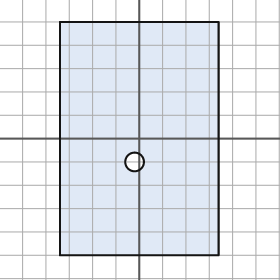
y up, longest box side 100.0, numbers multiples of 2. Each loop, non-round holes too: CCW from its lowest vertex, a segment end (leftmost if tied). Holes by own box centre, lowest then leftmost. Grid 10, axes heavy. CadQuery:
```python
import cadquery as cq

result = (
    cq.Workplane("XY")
    .moveTo(-34.0, -50.0)
    .lineTo(34.0, -50.0)
    .lineTo(34.0, 50.0)
    .lineTo(-34.0, 50.0)
    .close()
    .moveTo(-2.0, -10.0)
    .circle(4.0)
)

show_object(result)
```